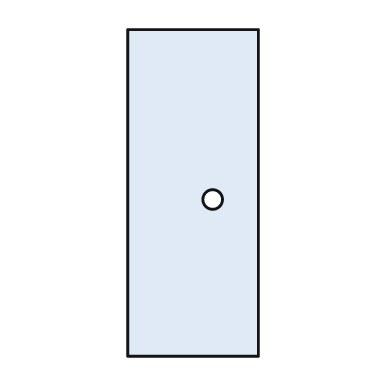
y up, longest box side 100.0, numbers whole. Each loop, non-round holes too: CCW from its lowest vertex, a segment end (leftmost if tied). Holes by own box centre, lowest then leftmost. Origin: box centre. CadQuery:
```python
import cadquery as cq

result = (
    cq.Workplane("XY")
    .moveTo(-20.0, -50.0)
    .lineTo(20.0, -50.0)
    .lineTo(20.0, 50.0)
    .lineTo(-20.0, 50.0)
    .close()
    .moveTo(6.0, -2.0)
    .circle(3.0)
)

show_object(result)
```